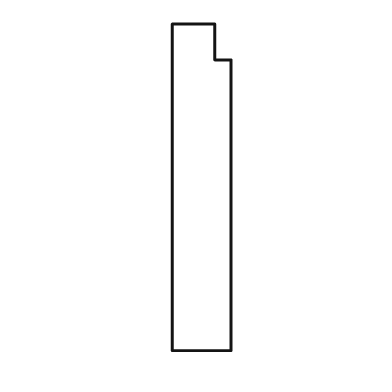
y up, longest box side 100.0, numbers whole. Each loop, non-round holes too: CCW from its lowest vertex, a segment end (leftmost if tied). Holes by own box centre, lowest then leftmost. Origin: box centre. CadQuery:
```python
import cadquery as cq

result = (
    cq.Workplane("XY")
    .moveTo(-9.0, -50.0)
    .lineTo(9.0, -50.0)
    .lineTo(9.0, 39.0)
    .lineTo(4.0, 39.0)
    .lineTo(4.0, 50.0)
    .lineTo(-9.0, 50.0)
    .close()
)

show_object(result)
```